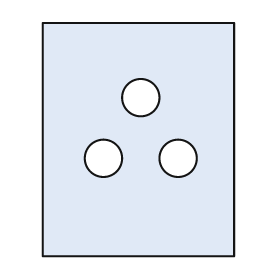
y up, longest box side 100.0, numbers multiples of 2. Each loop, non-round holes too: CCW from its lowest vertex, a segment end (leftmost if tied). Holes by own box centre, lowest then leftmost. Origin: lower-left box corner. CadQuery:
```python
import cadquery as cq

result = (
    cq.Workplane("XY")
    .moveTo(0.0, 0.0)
    .lineTo(82.0, 0.0)
    .lineTo(82.0, 100.0)
    .lineTo(0.0, 100.0)
    .close()
    .moveTo(26.0, 42.0)
    .circle(8.0)
    .moveTo(58.0, 42.0)
    .circle(8.0)
    .moveTo(42.0, 68.0)
    .circle(8.0)
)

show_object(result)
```